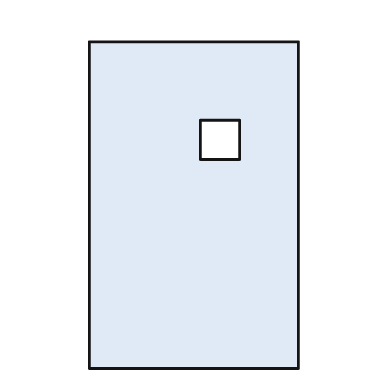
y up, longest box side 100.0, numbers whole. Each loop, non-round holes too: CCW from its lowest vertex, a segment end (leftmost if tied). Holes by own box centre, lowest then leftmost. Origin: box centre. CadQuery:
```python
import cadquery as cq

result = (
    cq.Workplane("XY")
    .moveTo(-32.0, -50.0)
    .lineTo(32.0, -50.0)
    .lineTo(32.0, 50.0)
    .lineTo(-32.0, 50.0)
    .close()
    .moveTo(2.0, 14.0)
    .lineTo(14.0, 14.0)
    .lineTo(14.0, 26.0)
    .lineTo(2.0, 26.0)
    .close()
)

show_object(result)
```